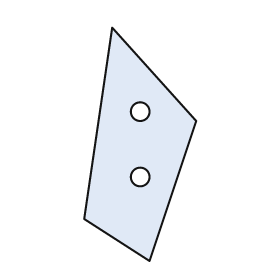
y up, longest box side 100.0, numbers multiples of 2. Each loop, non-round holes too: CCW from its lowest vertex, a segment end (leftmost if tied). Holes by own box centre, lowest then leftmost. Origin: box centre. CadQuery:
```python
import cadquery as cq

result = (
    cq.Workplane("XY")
    .moveTo(4.0, -50.0)
    .lineTo(24.0, 10.0)
    .lineTo(-12.0, 50.0)
    .lineTo(-24.0, -32.0)
    .close()
    .moveTo(0.0, -14.0)
    .circle(4.0)
    .moveTo(0.0, 14.0)
    .circle(4.0)
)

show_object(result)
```